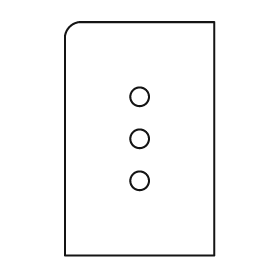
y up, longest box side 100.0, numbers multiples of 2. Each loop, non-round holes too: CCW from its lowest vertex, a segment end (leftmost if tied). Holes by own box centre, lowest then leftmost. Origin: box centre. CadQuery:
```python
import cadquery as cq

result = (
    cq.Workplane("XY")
    .moveTo(-32.0, -50.0)
    .lineTo(32.0, -50.0)
    .lineTo(32.0, 50.0)
    .lineTo(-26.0, 50.0)
    .threePointArc((-30.0, 48.0), (-32.0, 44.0))
    .close()
    .moveTo(0.0, -18.0)
    .circle(4.0)
    .moveTo(0.0, 0.0)
    .circle(4.0)
    .moveTo(0.0, 18.0)
    .circle(4.0)
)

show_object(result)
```